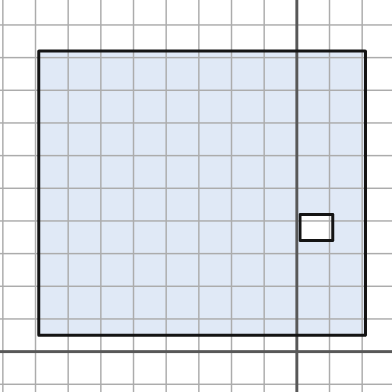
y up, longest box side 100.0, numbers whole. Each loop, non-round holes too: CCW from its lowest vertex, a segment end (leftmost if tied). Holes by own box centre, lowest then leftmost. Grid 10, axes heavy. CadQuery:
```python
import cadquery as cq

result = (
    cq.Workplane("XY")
    .moveTo(-79.0, 5.0)
    .lineTo(21.0, 5.0)
    .lineTo(21.0, 92.0)
    .lineTo(-79.0, 92.0)
    .close()
    .moveTo(1.0, 34.0)
    .lineTo(11.0, 34.0)
    .lineTo(11.0, 42.0)
    .lineTo(1.0, 42.0)
    .close()
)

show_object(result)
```